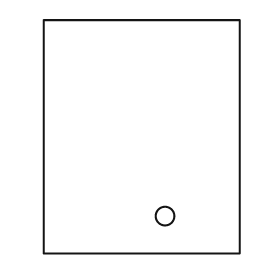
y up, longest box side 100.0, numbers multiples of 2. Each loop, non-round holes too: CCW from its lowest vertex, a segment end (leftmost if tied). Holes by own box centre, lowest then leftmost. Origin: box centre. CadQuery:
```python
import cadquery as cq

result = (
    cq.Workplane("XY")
    .moveTo(-42.0, -50.0)
    .lineTo(42.0, -50.0)
    .lineTo(42.0, 50.0)
    .lineTo(-42.0, 50.0)
    .close()
    .moveTo(10.0, -34.0)
    .circle(4.0)
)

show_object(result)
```